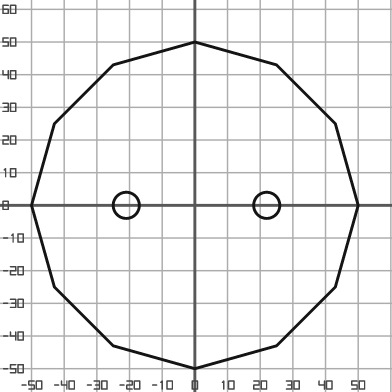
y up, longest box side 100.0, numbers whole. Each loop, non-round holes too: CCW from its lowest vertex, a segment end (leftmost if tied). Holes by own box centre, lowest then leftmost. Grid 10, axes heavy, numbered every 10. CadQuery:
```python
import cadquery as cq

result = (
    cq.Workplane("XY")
    .moveTo(0.0, -50.0)
    .lineTo(25.0, -43.0)
    .lineTo(43.0, -25.0)
    .lineTo(50.0, 0.0)
    .lineTo(43.0, 25.0)
    .lineTo(25.0, 43.0)
    .lineTo(0.0, 50.0)
    .lineTo(-25.0, 43.0)
    .lineTo(-43.0, 25.0)
    .lineTo(-50.0, 0.0)
    .lineTo(-43.0, -25.0)
    .lineTo(-25.0, -43.0)
    .close()
    .moveTo(-21.0, 0.0)
    .circle(4.0)
    .moveTo(22.0, 0.0)
    .circle(4.0)
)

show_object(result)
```